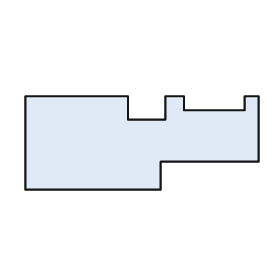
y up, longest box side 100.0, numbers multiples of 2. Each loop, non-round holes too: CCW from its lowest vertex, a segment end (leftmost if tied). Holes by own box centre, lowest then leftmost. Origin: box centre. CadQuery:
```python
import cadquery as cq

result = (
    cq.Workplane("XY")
    .moveTo(-50.0, -20.0)
    .lineTo(8.0, -20.0)
    .lineTo(8.0, -8.0)
    .lineTo(50.0, -8.0)
    .lineTo(50.0, 20.0)
    .lineTo(44.0, 20.0)
    .lineTo(44.0, 14.0)
    .lineTo(18.0, 14.0)
    .lineTo(18.0, 20.0)
    .lineTo(10.0, 20.0)
    .lineTo(10.0, 10.0)
    .lineTo(-6.0, 10.0)
    .lineTo(-6.0, 20.0)
    .lineTo(-50.0, 20.0)
    .close()
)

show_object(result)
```